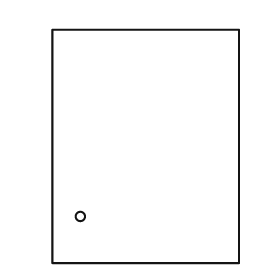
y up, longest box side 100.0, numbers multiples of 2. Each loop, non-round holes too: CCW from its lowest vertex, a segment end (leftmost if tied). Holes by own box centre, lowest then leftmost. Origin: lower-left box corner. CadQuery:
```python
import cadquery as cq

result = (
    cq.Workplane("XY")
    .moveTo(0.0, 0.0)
    .lineTo(80.0, 0.0)
    .lineTo(80.0, 100.0)
    .lineTo(0.0, 100.0)
    .close()
    .moveTo(12.0, 20.0)
    .circle(2.0)
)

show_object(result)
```